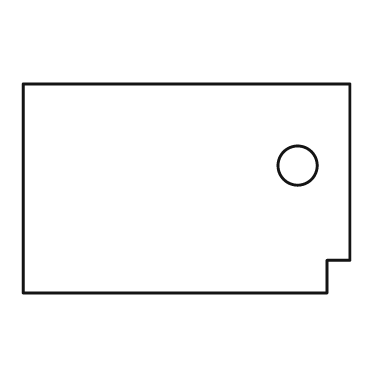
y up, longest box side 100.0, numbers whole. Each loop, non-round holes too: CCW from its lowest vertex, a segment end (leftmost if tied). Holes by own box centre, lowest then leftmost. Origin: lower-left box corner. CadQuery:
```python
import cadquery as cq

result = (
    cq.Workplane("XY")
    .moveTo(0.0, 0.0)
    .lineTo(93.0, 0.0)
    .lineTo(93.0, 10.0)
    .lineTo(100.0, 10.0)
    .lineTo(100.0, 64.0)
    .lineTo(0.0, 64.0)
    .close()
    .moveTo(84.0, 39.0)
    .circle(6.0)
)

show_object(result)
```